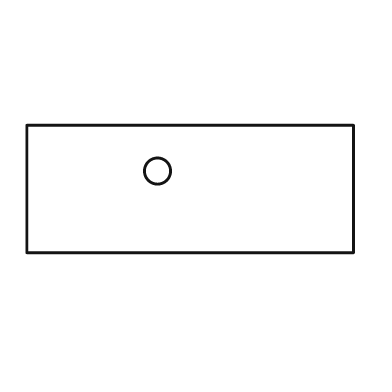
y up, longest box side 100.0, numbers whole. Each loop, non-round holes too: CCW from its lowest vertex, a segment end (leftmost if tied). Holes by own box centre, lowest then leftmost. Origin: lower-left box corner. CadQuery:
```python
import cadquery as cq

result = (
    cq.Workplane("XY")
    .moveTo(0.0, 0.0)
    .lineTo(100.0, 0.0)
    .lineTo(100.0, 39.0)
    .lineTo(0.0, 39.0)
    .close()
    .moveTo(40.0, 25.0)
    .circle(4.0)
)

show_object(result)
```